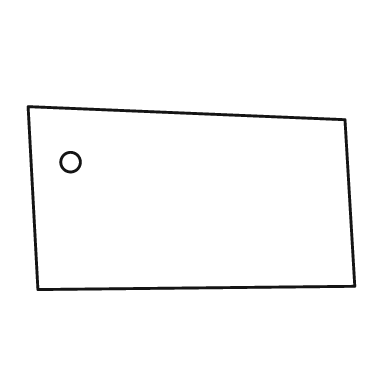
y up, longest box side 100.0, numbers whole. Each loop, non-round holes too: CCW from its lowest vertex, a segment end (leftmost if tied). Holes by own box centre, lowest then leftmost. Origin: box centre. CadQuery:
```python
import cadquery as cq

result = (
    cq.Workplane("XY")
    .moveTo(-47.0, -28.0)
    .lineTo(50.0, -27.0)
    .lineTo(47.0, 24.0)
    .lineTo(-50.0, 28.0)
    .close()
    .moveTo(-37.0, 11.0)
    .circle(3.0)
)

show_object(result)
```